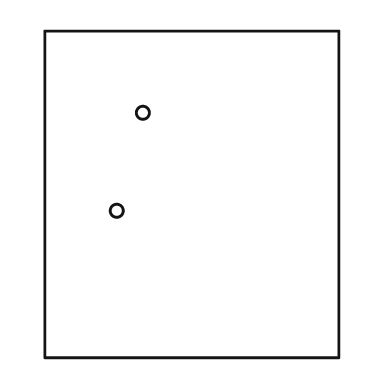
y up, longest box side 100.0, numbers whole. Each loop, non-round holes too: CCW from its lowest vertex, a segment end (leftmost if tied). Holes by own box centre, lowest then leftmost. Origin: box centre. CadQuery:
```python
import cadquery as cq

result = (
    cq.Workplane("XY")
    .moveTo(-45.0, -50.0)
    .lineTo(45.0, -50.0)
    .lineTo(45.0, 50.0)
    .lineTo(-45.0, 50.0)
    .close()
    .moveTo(-23.0, -5.0)
    .circle(2.0)
    .moveTo(-15.0, 25.0)
    .circle(2.0)
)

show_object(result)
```